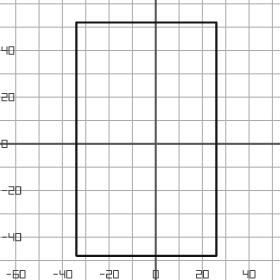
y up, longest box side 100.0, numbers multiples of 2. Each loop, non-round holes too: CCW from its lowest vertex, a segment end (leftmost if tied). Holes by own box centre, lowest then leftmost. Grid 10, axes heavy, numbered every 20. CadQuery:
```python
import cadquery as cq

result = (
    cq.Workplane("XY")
    .moveTo(-34.0, -48.0)
    .lineTo(26.0, -48.0)
    .lineTo(26.0, 52.0)
    .lineTo(-34.0, 52.0)
    .close()
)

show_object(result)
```